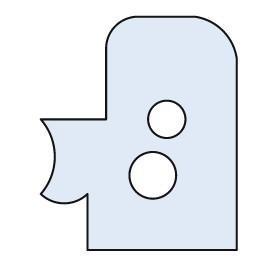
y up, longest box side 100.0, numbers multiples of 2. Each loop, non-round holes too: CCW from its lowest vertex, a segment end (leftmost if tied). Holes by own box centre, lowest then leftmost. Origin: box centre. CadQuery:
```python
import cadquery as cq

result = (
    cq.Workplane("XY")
    .moveTo(-22.0, -50.0)
    .lineTo(42.0, -50.0)
    .lineTo(42.0, 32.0)
    .threePointArc((36.0, 44.0), (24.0, 50.0))
    .lineTo(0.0, 50.0)
    .threePointArc((-10.0, 46.0), (-14.0, 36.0))
    .lineTo(-14.0, 6.0)
    .lineTo(-42.0, 6.0)
    .threePointArc((-36.0, -10.0), (-42.0, -26.0))
    .threePointArc((-32.0, -30.0), (-22.0, -26.0))
    .close()
    .moveTo(6.0, -18.0)
    .circle(10.0)
    .moveTo(12.0, 6.0)
    .circle(8.0)
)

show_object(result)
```